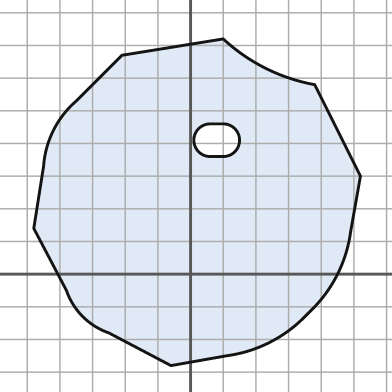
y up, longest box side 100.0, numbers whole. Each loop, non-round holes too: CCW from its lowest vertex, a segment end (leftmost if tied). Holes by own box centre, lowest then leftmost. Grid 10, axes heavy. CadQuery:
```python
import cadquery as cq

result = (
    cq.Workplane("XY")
    .moveTo(-6.0, -28.0)
    .lineTo(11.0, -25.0)
    .threePointArc((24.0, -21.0), (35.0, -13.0))
    .lineTo(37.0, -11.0)
    .threePointArc((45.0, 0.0), (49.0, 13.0))
    .lineTo(52.0, 30.0)
    .lineTo(38.0, 58.0)
    .threePointArc((23.0, 63.0), (10.0, 72.0))
    .lineTo(-21.0, 67.0)
    .lineTo(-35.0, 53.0)
    .threePointArc((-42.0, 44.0), (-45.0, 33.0))
    .lineTo(-48.0, 14.0)
    .lineTo(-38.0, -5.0)
    .threePointArc((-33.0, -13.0), (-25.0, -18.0))
    .close()
    .moveTo(6.0, 36.0)
    .lineTo(10.0, 36.0)
    .threePointArc((15.0, 41.0), (10.0, 46.0))
    .lineTo(6.0, 46.0)
    .threePointArc((1.0, 41.0), (6.0, 36.0))
    .close()
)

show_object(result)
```